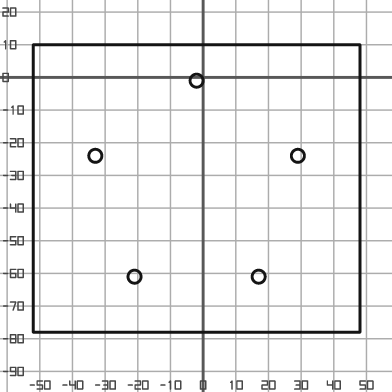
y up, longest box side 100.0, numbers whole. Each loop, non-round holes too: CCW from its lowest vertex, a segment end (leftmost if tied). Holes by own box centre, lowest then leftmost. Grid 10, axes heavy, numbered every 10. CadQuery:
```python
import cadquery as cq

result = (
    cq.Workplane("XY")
    .moveTo(-52.0, -78.0)
    .lineTo(48.0, -78.0)
    .lineTo(48.0, 10.0)
    .lineTo(-52.0, 10.0)
    .close()
    .moveTo(-21.0, -61.0)
    .circle(2.0)
    .moveTo(17.0, -61.0)
    .circle(2.0)
    .moveTo(-33.0, -24.0)
    .circle(2.0)
    .moveTo(29.0, -24.0)
    .circle(2.0)
    .moveTo(-2.0, -1.0)
    .circle(2.0)
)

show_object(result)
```